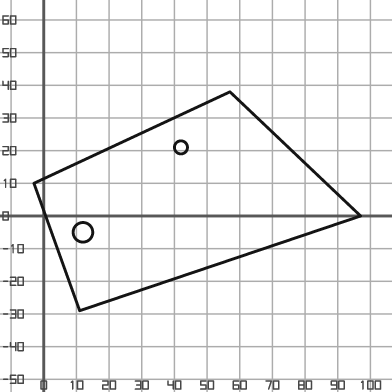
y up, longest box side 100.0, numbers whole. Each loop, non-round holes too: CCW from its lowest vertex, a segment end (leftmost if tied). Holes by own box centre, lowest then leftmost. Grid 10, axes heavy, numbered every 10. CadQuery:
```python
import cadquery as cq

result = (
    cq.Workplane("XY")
    .moveTo(11.0, -29.0)
    .lineTo(97.0, 0.0)
    .lineTo(57.0, 38.0)
    .lineTo(-3.0, 10.0)
    .close()
    .moveTo(12.0, -5.0)
    .circle(3.0)
    .moveTo(42.0, 21.0)
    .circle(2.0)
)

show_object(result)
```